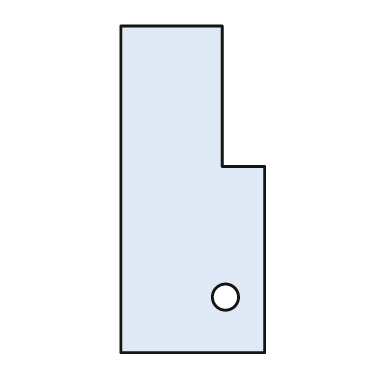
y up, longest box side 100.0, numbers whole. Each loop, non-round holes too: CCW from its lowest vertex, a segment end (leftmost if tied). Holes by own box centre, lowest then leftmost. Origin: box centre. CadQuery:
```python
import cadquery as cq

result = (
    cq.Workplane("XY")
    .moveTo(-22.0, -50.0)
    .lineTo(22.0, -50.0)
    .lineTo(22.0, 7.0)
    .lineTo(9.0, 7.0)
    .lineTo(9.0, 50.0)
    .lineTo(-22.0, 50.0)
    .close()
    .moveTo(10.0, -33.0)
    .circle(4.0)
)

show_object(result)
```